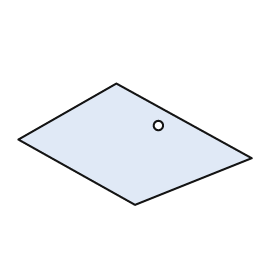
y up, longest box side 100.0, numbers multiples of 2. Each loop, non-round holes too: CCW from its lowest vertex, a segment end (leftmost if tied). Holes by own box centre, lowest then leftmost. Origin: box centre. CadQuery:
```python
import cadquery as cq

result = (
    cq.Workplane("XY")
    .moveTo(0.0, -26.0)
    .lineTo(50.0, -6.0)
    .lineTo(-8.0, 26.0)
    .lineTo(-50.0, 2.0)
    .close()
    .moveTo(10.0, 8.0)
    .circle(2.0)
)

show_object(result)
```